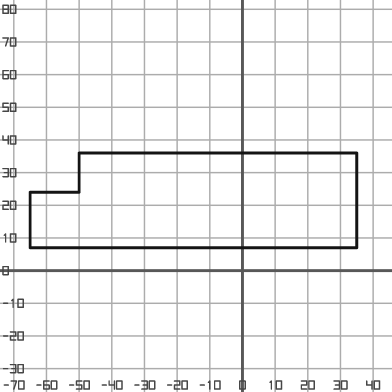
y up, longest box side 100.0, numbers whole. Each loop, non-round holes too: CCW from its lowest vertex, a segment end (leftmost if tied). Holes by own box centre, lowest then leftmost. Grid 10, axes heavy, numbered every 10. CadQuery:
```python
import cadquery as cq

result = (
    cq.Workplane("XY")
    .moveTo(-65.0, 7.0)
    .lineTo(35.0, 7.0)
    .lineTo(35.0, 36.0)
    .lineTo(-50.0, 36.0)
    .lineTo(-50.0, 24.0)
    .lineTo(-65.0, 24.0)
    .close()
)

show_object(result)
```